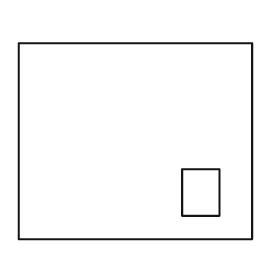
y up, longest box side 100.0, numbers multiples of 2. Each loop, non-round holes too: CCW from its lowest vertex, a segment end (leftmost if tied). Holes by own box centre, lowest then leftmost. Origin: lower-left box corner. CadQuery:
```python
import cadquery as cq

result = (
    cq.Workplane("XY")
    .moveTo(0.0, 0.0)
    .lineTo(100.0, 0.0)
    .lineTo(100.0, 84.0)
    .lineTo(0.0, 84.0)
    .close()
    .moveTo(70.0, 10.0)
    .lineTo(86.0, 10.0)
    .lineTo(86.0, 30.0)
    .lineTo(70.0, 30.0)
    .close()
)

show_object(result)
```